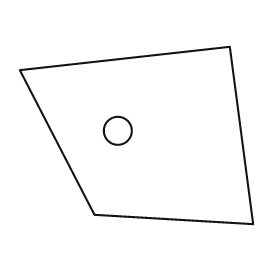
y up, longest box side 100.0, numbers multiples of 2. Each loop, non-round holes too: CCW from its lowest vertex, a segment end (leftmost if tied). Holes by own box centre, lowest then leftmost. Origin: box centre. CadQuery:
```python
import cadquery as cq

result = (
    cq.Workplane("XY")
    .moveTo(50.0, -38.0)
    .lineTo(40.0, 38.0)
    .lineTo(-50.0, 28.0)
    .lineTo(-18.0, -34.0)
    .close()
    .moveTo(-8.0, 2.0)
    .circle(6.0)
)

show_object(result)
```